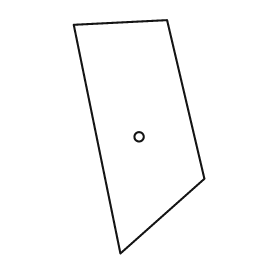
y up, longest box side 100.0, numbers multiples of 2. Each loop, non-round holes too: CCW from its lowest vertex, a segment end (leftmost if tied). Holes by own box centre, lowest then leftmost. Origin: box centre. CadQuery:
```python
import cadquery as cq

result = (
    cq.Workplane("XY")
    .moveTo(-8.0, -50.0)
    .lineTo(28.0, -18.0)
    .lineTo(12.0, 50.0)
    .lineTo(-28.0, 48.0)
    .close()
    .moveTo(0.0, 0.0)
    .circle(2.0)
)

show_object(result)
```